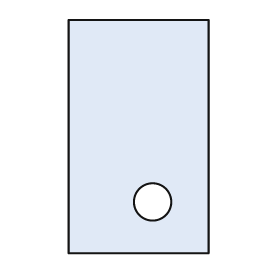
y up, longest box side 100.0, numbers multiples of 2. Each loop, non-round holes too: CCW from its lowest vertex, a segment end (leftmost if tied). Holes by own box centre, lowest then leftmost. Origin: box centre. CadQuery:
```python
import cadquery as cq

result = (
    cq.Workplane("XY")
    .moveTo(-30.0, -50.0)
    .lineTo(30.0, -50.0)
    .lineTo(30.0, 50.0)
    .lineTo(-30.0, 50.0)
    .close()
    .moveTo(6.0, -28.0)
    .circle(8.0)
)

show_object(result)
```